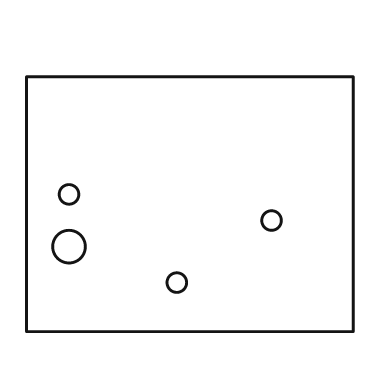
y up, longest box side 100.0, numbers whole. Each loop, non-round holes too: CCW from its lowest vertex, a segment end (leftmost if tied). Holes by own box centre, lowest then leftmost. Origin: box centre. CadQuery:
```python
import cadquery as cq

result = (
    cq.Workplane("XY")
    .moveTo(-50.0, -39.0)
    .lineTo(50.0, -39.0)
    .lineTo(50.0, 39.0)
    .lineTo(-50.0, 39.0)
    .close()
    .moveTo(-4.0, -24.0)
    .circle(3.0)
    .moveTo(-37.0, -13.0)
    .circle(5.0)
    .moveTo(25.0, -5.0)
    .circle(3.0)
    .moveTo(-37.0, 3.0)
    .circle(3.0)
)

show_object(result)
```